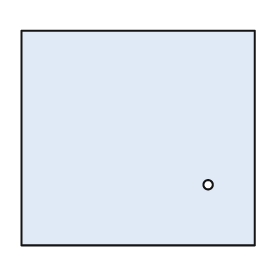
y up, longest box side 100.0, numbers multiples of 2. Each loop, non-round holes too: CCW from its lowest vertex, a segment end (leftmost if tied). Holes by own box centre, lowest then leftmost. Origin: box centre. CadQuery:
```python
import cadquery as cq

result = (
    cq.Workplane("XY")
    .moveTo(-50.0, -46.0)
    .lineTo(50.0, -46.0)
    .lineTo(50.0, 46.0)
    .lineTo(-50.0, 46.0)
    .close()
    .moveTo(30.0, -20.0)
    .circle(2.0)
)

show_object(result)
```